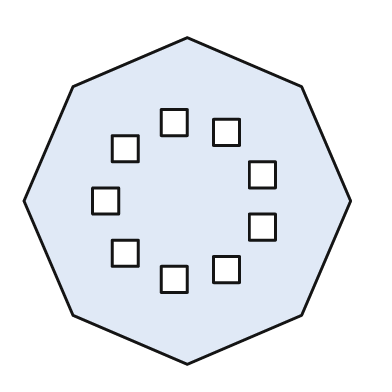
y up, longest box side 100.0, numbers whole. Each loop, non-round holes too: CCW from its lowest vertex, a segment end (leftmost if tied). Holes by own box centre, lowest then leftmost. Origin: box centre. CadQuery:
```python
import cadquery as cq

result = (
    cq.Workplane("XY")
    .moveTo(0.0, -50.0)
    .lineTo(35.0, -35.0)
    .lineTo(50.0, 0.0)
    .lineTo(35.0, 35.0)
    .lineTo(0.0, 50.0)
    .lineTo(-35.0, 35.0)
    .lineTo(-50.0, 0.0)
    .lineTo(-35.0, -35.0)
    .close()
    .moveTo(-8.0, -28.0)
    .lineTo(0.0, -28.0)
    .lineTo(0.0, -20.0)
    .lineTo(-8.0, -20.0)
    .close()
    .moveTo(8.0, -25.0)
    .lineTo(16.0, -25.0)
    .lineTo(16.0, -17.0)
    .lineTo(8.0, -17.0)
    .close()
    .moveTo(-23.0, -20.0)
    .lineTo(-15.0, -20.0)
    .lineTo(-15.0, -12.0)
    .lineTo(-23.0, -12.0)
    .close()
    .moveTo(19.0, -12.0)
    .lineTo(27.0, -12.0)
    .lineTo(27.0, -4.0)
    .lineTo(19.0, -4.0)
    .close()
    .moveTo(-29.0, -4.0)
    .lineTo(-21.0, -4.0)
    .lineTo(-21.0, 4.0)
    .lineTo(-29.0, 4.0)
    .close()
    .moveTo(19.0, 4.0)
    .lineTo(27.0, 4.0)
    .lineTo(27.0, 12.0)
    .lineTo(19.0, 12.0)
    .close()
    .moveTo(-23.0, 12.0)
    .lineTo(-15.0, 12.0)
    .lineTo(-15.0, 20.0)
    .lineTo(-23.0, 20.0)
    .close()
    .moveTo(8.0, 17.0)
    .lineTo(16.0, 17.0)
    .lineTo(16.0, 25.0)
    .lineTo(8.0, 25.0)
    .close()
    .moveTo(-8.0, 20.0)
    .lineTo(0.0, 20.0)
    .lineTo(0.0, 28.0)
    .lineTo(-8.0, 28.0)
    .close()
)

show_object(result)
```